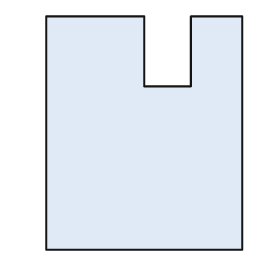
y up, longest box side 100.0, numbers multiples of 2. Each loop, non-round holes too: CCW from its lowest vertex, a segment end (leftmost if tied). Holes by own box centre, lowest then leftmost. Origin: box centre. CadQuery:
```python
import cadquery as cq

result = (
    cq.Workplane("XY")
    .moveTo(-42.0, -50.0)
    .lineTo(42.0, -50.0)
    .lineTo(42.0, 50.0)
    .lineTo(20.0, 50.0)
    .lineTo(20.0, 20.0)
    .lineTo(0.0, 20.0)
    .lineTo(0.0, 50.0)
    .lineTo(-42.0, 50.0)
    .close()
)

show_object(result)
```